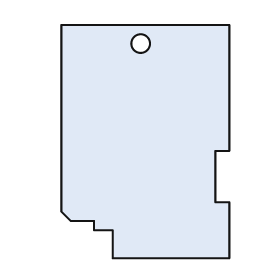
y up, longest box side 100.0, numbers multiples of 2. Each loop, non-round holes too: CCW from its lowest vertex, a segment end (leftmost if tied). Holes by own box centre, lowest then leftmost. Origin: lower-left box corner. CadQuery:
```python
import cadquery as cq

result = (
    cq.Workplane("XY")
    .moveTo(22.0, 0.0)
    .lineTo(72.0, 0.0)
    .lineTo(72.0, 24.0)
    .lineTo(66.0, 24.0)
    .lineTo(66.0, 46.0)
    .lineTo(72.0, 46.0)
    .lineTo(72.0, 100.0)
    .lineTo(0.0, 100.0)
    .lineTo(0.0, 20.0)
    .lineTo(4.0, 16.0)
    .lineTo(14.0, 16.0)
    .lineTo(14.0, 12.0)
    .lineTo(22.0, 12.0)
    .close()
    .moveTo(34.0, 92.0)
    .circle(4.0)
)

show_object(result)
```